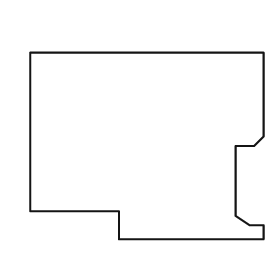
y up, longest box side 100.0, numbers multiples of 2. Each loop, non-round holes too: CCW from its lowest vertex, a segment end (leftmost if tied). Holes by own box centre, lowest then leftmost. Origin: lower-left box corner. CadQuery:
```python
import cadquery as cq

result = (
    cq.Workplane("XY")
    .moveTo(38.0, 0.0)
    .lineTo(100.0, 0.0)
    .lineTo(100.0, 6.0)
    .lineTo(94.0, 6.0)
    .lineTo(88.0, 10.0)
    .lineTo(88.0, 40.0)
    .lineTo(96.0, 40.0)
    .lineTo(100.0, 44.0)
    .lineTo(100.0, 80.0)
    .lineTo(0.0, 80.0)
    .lineTo(0.0, 12.0)
    .lineTo(38.0, 12.0)
    .close()
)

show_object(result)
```